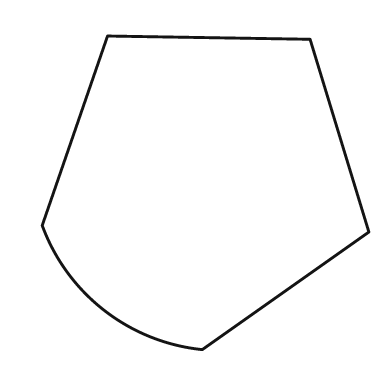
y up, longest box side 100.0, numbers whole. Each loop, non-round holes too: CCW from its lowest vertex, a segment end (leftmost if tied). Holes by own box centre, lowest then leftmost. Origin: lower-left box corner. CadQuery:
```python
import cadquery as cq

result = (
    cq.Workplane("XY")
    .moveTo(49.0, 0.0)
    .lineTo(100.0, 36.0)
    .lineTo(82.0, 95.0)
    .lineTo(20.0, 96.0)
    .lineTo(0.0, 38.0)
    .threePointArc((19.0, 12.0), (49.0, 0.0))
    .close()
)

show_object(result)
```